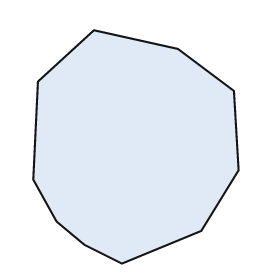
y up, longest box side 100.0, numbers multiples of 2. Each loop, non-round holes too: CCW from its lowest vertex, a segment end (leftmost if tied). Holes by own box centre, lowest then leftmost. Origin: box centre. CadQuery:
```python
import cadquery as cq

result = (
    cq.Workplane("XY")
    .moveTo(-6.0, -50.0)
    .lineTo(28.0, -36.0)
    .lineTo(44.0, -10.0)
    .lineTo(42.0, 24.0)
    .lineTo(18.0, 42.0)
    .lineTo(-18.0, 50.0)
    .lineTo(-42.0, 28.0)
    .lineTo(-44.0, -14.0)
    .lineTo(-34.0, -32.0)
    .lineTo(-22.0, -42.0)
    .close()
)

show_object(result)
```